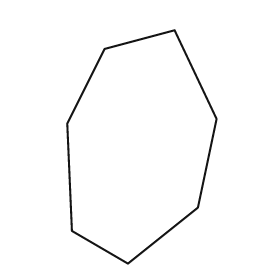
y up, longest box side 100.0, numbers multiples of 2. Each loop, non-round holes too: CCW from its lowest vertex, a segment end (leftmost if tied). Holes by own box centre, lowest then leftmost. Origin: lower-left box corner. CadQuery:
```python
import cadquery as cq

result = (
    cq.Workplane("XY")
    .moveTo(26.0, 0.0)
    .lineTo(56.0, 24.0)
    .lineTo(64.0, 62.0)
    .lineTo(46.0, 100.0)
    .lineTo(16.0, 92.0)
    .lineTo(0.0, 60.0)
    .lineTo(2.0, 14.0)
    .close()
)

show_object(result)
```